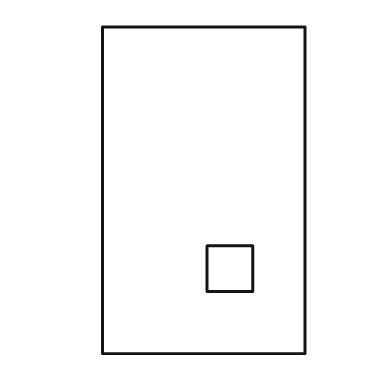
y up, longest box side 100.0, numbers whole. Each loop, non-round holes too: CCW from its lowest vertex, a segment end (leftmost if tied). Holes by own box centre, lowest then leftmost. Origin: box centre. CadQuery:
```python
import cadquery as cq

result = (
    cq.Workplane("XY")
    .moveTo(-31.0, -50.0)
    .lineTo(31.0, -50.0)
    .lineTo(31.0, 50.0)
    .lineTo(-31.0, 50.0)
    .close()
    .moveTo(1.0, -31.0)
    .lineTo(15.0, -31.0)
    .lineTo(15.0, -17.0)
    .lineTo(1.0, -17.0)
    .close()
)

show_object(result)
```